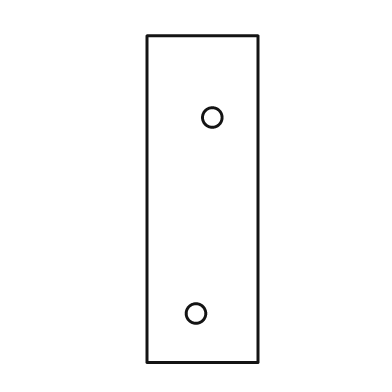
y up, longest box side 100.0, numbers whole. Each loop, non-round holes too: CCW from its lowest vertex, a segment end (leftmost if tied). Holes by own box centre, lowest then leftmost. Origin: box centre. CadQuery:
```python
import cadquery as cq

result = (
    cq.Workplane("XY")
    .moveTo(-17.0, -50.0)
    .lineTo(17.0, -50.0)
    .lineTo(17.0, 50.0)
    .lineTo(-17.0, 50.0)
    .close()
    .moveTo(-2.0, -35.0)
    .circle(3.0)
    .moveTo(3.0, 25.0)
    .circle(3.0)
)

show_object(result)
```